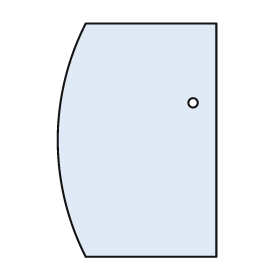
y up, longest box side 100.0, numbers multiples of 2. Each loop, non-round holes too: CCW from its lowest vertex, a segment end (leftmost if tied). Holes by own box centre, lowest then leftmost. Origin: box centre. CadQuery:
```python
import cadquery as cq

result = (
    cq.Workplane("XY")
    .moveTo(-22.0, -50.0)
    .lineTo(34.0, -50.0)
    .lineTo(34.0, 50.0)
    .lineTo(-22.0, 50.0)
    .threePointArc((-34.0, 0.0), (-22.0, -50.0))
    .close()
    .moveTo(24.0, 16.0)
    .circle(2.0)
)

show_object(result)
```